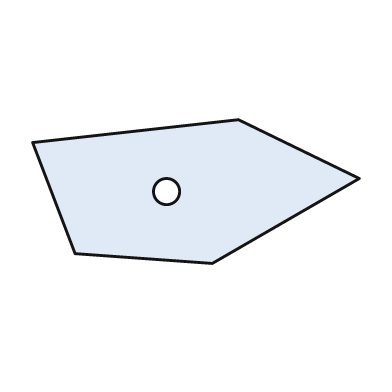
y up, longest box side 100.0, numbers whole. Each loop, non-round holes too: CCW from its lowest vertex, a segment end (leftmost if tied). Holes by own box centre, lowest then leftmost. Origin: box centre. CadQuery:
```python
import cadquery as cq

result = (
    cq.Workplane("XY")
    .moveTo(5.0, -22.0)
    .lineTo(50.0, 4.0)
    .lineTo(13.0, 22.0)
    .lineTo(-50.0, 15.0)
    .lineTo(-37.0, -19.0)
    .close()
    .moveTo(-9.0, 0.0)
    .circle(4.0)
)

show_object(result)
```